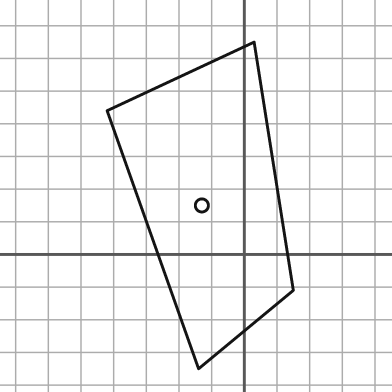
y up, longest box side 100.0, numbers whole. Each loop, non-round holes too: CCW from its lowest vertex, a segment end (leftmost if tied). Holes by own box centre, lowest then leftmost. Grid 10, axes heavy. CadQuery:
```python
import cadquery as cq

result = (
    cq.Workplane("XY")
    .moveTo(-14.0, -35.0)
    .lineTo(15.0, -11.0)
    .lineTo(3.0, 65.0)
    .lineTo(-42.0, 44.0)
    .close()
    .moveTo(-13.0, 15.0)
    .circle(2.0)
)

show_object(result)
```